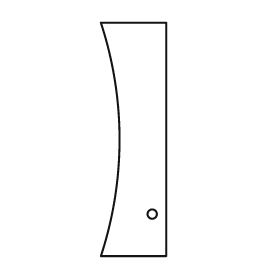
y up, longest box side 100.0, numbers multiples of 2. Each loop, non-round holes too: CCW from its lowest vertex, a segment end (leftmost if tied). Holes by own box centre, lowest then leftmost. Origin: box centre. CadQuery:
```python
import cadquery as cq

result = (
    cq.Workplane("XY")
    .moveTo(-14.0, -50.0)
    .lineTo(14.0, -50.0)
    .lineTo(14.0, 50.0)
    .lineTo(-14.0, 50.0)
    .threePointArc((-6.0, 0.0), (-14.0, -50.0))
    .close()
    .moveTo(8.0, -32.0)
    .circle(2.0)
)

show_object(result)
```